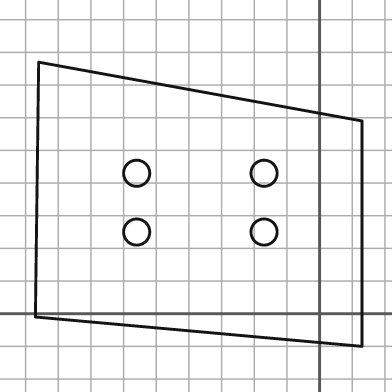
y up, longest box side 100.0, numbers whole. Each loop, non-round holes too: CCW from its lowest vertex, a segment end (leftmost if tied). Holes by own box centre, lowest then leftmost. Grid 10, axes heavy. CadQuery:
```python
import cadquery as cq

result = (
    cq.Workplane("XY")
    .moveTo(13.0, -10.0)
    .lineTo(13.0, 59.0)
    .lineTo(-86.0, 77.0)
    .lineTo(-87.0, -1.0)
    .close()
    .moveTo(-56.0, 25.0)
    .circle(4.0)
    .moveTo(-17.0, 25.0)
    .circle(4.0)
    .moveTo(-56.0, 43.0)
    .circle(4.0)
    .moveTo(-17.0, 43.0)
    .circle(4.0)
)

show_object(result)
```